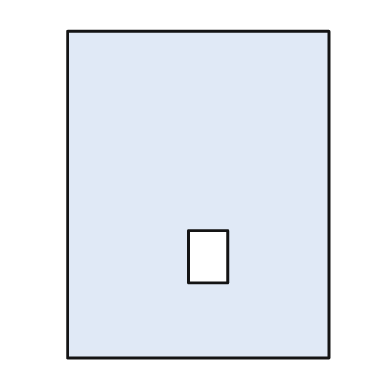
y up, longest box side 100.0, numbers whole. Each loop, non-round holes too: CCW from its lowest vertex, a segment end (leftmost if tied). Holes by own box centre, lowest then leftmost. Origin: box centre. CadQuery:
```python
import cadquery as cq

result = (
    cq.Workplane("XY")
    .moveTo(-40.0, -50.0)
    .lineTo(40.0, -50.0)
    .lineTo(40.0, 50.0)
    .lineTo(-40.0, 50.0)
    .close()
    .moveTo(-3.0, -27.0)
    .lineTo(9.0, -27.0)
    .lineTo(9.0, -11.0)
    .lineTo(-3.0, -11.0)
    .close()
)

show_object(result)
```